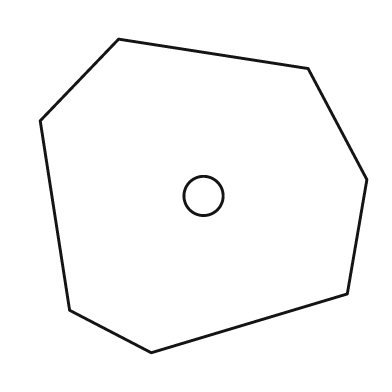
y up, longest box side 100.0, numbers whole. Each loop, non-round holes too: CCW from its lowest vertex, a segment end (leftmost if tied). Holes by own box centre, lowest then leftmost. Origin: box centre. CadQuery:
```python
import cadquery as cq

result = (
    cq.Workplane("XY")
    .moveTo(-16.0, -48.0)
    .lineTo(44.0, -30.0)
    .lineTo(50.0, 5.0)
    .lineTo(32.0, 39.0)
    .lineTo(-26.0, 48.0)
    .lineTo(-50.0, 23.0)
    .lineTo(-41.0, -35.0)
    .close()
    .moveTo(0.0, 0.0)
    .circle(6.0)
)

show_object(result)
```